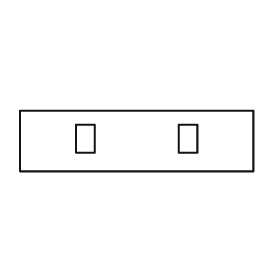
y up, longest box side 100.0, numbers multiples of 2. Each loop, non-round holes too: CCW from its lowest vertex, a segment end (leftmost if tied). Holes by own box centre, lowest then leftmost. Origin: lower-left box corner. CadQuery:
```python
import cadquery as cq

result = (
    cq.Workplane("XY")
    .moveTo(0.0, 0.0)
    .lineTo(100.0, 0.0)
    .lineTo(100.0, 26.0)
    .lineTo(0.0, 26.0)
    .close()
    .moveTo(24.0, 8.0)
    .lineTo(32.0, 8.0)
    .lineTo(32.0, 20.0)
    .lineTo(24.0, 20.0)
    .close()
    .moveTo(68.0, 8.0)
    .lineTo(76.0, 8.0)
    .lineTo(76.0, 20.0)
    .lineTo(68.0, 20.0)
    .close()
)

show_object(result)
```